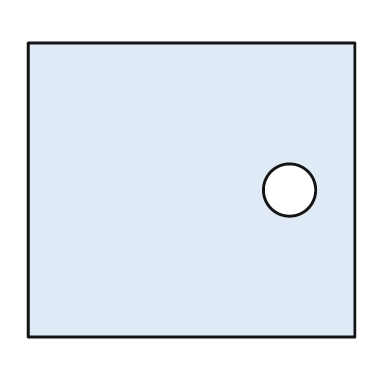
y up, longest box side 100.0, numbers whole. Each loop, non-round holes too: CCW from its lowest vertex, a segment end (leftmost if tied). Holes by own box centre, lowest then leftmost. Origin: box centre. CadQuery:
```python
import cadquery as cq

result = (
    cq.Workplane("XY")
    .moveTo(-50.0, -45.0)
    .lineTo(50.0, -45.0)
    .lineTo(50.0, 45.0)
    .lineTo(-50.0, 45.0)
    .close()
    .moveTo(30.0, 0.0)
    .circle(8.0)
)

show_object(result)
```